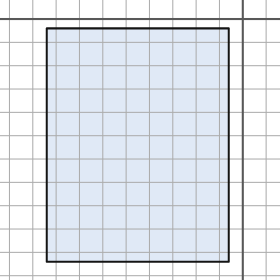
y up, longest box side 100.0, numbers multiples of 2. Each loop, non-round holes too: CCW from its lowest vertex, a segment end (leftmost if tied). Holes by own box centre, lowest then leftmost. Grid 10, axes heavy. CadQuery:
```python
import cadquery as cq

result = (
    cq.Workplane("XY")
    .moveTo(-84.0, -104.0)
    .lineTo(-6.0, -104.0)
    .lineTo(-6.0, -4.0)
    .lineTo(-84.0, -4.0)
    .close()
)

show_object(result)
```